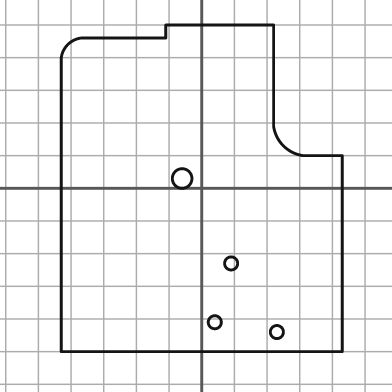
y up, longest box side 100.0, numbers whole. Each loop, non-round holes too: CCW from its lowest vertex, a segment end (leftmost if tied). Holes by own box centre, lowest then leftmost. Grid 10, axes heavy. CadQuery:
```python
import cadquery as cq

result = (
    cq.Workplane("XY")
    .moveTo(-43.0, -50.0)
    .lineTo(43.0, -50.0)
    .lineTo(43.0, 10.0)
    .lineTo(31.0, 10.0)
    .threePointArc((25.0, 13.0), (22.0, 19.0))
    .lineTo(22.0, 50.0)
    .lineTo(-11.0, 50.0)
    .lineTo(-11.0, 46.0)
    .lineTo(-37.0, 46.0)
    .threePointArc((-41.0, 44.0), (-43.0, 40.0))
    .close()
    .moveTo(23.0, -44.0)
    .circle(2.0)
    .moveTo(4.0, -41.0)
    .circle(2.0)
    .moveTo(9.0, -23.0)
    .circle(2.0)
    .moveTo(-6.0, 3.0)
    .circle(3.0)
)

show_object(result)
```